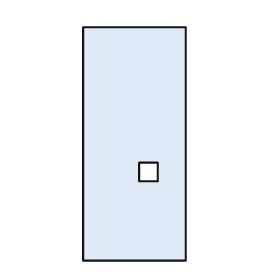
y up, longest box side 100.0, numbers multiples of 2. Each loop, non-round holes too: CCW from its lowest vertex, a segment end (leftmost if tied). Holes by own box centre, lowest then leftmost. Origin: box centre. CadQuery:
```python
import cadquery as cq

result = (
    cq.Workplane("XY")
    .moveTo(-22.0, -50.0)
    .lineTo(22.0, -50.0)
    .lineTo(22.0, 50.0)
    .lineTo(-22.0, 50.0)
    .close()
    .moveTo(2.0, -16.0)
    .lineTo(10.0, -16.0)
    .lineTo(10.0, -8.0)
    .lineTo(2.0, -8.0)
    .close()
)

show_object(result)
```